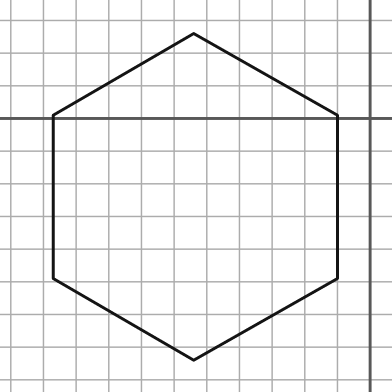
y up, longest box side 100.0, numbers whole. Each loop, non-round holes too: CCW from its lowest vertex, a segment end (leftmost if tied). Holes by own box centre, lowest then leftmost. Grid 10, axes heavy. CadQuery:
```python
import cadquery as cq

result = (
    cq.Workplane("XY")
    .moveTo(-54.0, -74.0)
    .lineTo(-10.0, -49.0)
    .lineTo(-10.0, 1.0)
    .lineTo(-54.0, 26.0)
    .lineTo(-97.0, 1.0)
    .lineTo(-97.0, -49.0)
    .close()
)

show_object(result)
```